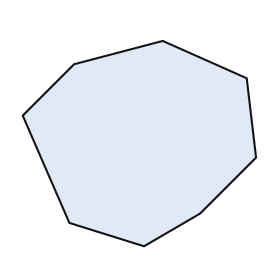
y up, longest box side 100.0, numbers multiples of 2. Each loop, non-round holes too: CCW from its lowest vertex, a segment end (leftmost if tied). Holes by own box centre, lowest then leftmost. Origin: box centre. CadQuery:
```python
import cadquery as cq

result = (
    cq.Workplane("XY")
    .moveTo(2.0, -44.0)
    .lineTo(26.0, -30.0)
    .lineTo(50.0, -6.0)
    .lineTo(46.0, 28.0)
    .lineTo(10.0, 44.0)
    .lineTo(-28.0, 34.0)
    .lineTo(-50.0, 12.0)
    .lineTo(-30.0, -34.0)
    .close()
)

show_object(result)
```